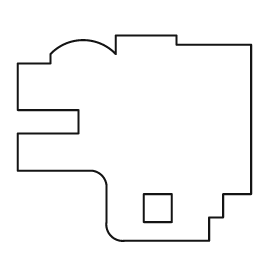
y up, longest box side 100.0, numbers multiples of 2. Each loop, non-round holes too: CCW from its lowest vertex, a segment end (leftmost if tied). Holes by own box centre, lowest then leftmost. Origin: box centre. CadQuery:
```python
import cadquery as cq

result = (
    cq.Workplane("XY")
    .moveTo(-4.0, -44.0)
    .lineTo(32.0, -44.0)
    .lineTo(32.0, -34.0)
    .lineTo(38.0, -34.0)
    .lineTo(38.0, -24.0)
    .lineTo(50.0, -24.0)
    .lineTo(50.0, 40.0)
    .lineTo(18.0, 40.0)
    .lineTo(18.0, 44.0)
    .lineTo(-8.0, 44.0)
    .lineTo(-8.0, 36.0)
    .threePointArc((-22.0, 42.0), (-36.0, 36.0))
    .lineTo(-36.0, 32.0)
    .lineTo(-50.0, 32.0)
    .lineTo(-50.0, 12.0)
    .lineTo(-24.0, 12.0)
    .lineTo(-24.0, 2.0)
    .lineTo(-50.0, 2.0)
    .lineTo(-50.0, -14.0)
    .lineTo(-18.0, -14.0)
    .threePointArc((-14.0, -16.0), (-12.0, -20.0))
    .lineTo(-12.0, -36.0)
    .threePointArc((-10.0, -42.0), (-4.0, -44.0))
    .close()
    .moveTo(4.0, -36.0)
    .lineTo(16.0, -36.0)
    .lineTo(16.0, -24.0)
    .lineTo(4.0, -24.0)
    .close()
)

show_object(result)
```